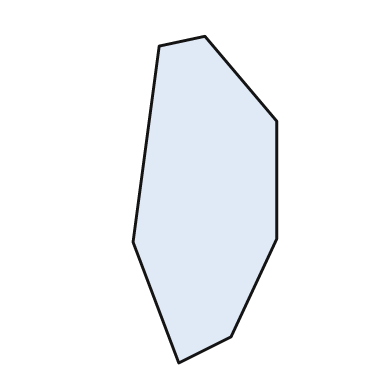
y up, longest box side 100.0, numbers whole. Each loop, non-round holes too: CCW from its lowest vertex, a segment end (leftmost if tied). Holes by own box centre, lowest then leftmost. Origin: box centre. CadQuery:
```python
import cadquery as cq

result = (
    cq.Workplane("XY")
    .moveTo(-8.0, -50.0)
    .lineTo(8.0, -42.0)
    .lineTo(22.0, -12.0)
    .lineTo(22.0, 24.0)
    .lineTo(0.0, 50.0)
    .lineTo(-14.0, 47.0)
    .lineTo(-22.0, -13.0)
    .close()
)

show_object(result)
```